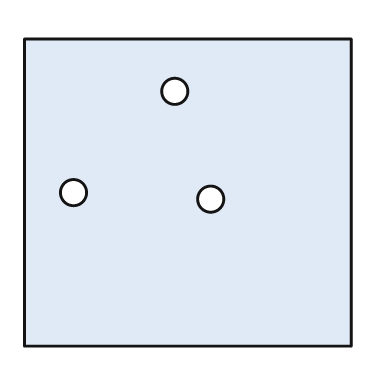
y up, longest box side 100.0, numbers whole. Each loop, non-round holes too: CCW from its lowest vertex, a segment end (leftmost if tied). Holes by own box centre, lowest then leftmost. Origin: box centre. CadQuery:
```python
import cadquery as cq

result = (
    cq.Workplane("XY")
    .moveTo(-50.0, -47.0)
    .lineTo(50.0, -47.0)
    .lineTo(50.0, 47.0)
    .lineTo(-50.0, 47.0)
    .close()
    .moveTo(7.0, -2.0)
    .circle(4.0)
    .moveTo(-35.0, 0.0)
    .circle(4.0)
    .moveTo(-4.0, 31.0)
    .circle(4.0)
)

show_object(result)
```